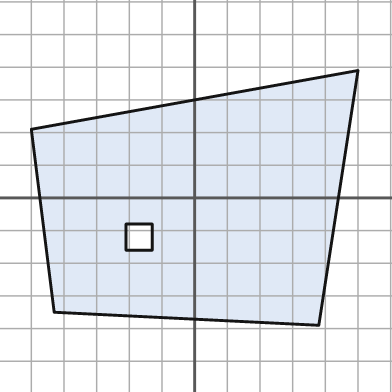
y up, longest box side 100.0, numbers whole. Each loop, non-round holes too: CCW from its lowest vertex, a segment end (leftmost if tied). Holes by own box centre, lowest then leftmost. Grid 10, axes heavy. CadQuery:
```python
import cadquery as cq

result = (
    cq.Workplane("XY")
    .moveTo(38.0, -39.0)
    .lineTo(50.0, 39.0)
    .lineTo(-50.0, 21.0)
    .lineTo(-43.0, -35.0)
    .close()
    .moveTo(-21.0, -16.0)
    .lineTo(-13.0, -16.0)
    .lineTo(-13.0, -8.0)
    .lineTo(-21.0, -8.0)
    .close()
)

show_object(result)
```